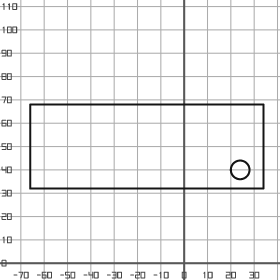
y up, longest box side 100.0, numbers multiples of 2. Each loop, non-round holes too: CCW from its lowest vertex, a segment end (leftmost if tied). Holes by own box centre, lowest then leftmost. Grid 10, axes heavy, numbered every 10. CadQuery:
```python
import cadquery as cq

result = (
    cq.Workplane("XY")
    .moveTo(-66.0, 32.0)
    .lineTo(34.0, 32.0)
    .lineTo(34.0, 68.0)
    .lineTo(-66.0, 68.0)
    .close()
    .moveTo(24.0, 40.0)
    .circle(4.0)
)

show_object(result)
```